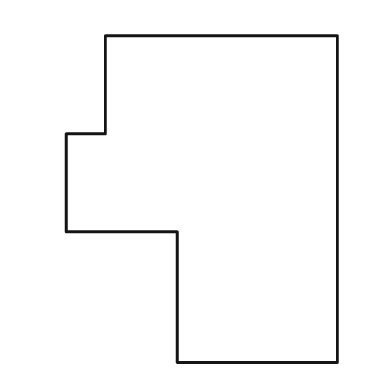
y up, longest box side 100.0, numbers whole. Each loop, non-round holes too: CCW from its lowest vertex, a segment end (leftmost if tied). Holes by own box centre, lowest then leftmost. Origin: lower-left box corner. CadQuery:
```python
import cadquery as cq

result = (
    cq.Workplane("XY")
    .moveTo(34.0, 0.0)
    .lineTo(83.0, 0.0)
    .lineTo(83.0, 100.0)
    .lineTo(12.0, 100.0)
    .lineTo(12.0, 70.0)
    .lineTo(0.0, 70.0)
    .lineTo(0.0, 40.0)
    .lineTo(34.0, 40.0)
    .close()
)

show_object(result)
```